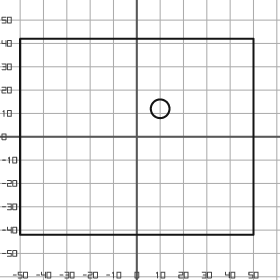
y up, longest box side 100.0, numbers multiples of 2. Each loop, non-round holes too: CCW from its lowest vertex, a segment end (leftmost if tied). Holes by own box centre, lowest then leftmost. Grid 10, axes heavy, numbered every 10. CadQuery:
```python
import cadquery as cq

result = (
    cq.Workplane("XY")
    .moveTo(-50.0, -42.0)
    .lineTo(50.0, -42.0)
    .lineTo(50.0, 42.0)
    .lineTo(-50.0, 42.0)
    .close()
    .moveTo(10.0, 12.0)
    .circle(4.0)
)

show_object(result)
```